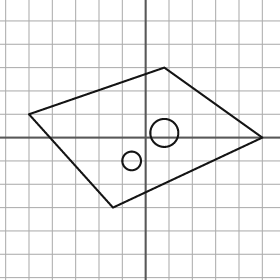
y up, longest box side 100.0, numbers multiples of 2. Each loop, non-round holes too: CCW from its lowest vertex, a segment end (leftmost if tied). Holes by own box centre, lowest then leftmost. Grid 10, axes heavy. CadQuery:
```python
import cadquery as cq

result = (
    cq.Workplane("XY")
    .moveTo(-14.0, -30.0)
    .lineTo(50.0, 0.0)
    .lineTo(8.0, 30.0)
    .lineTo(-50.0, 10.0)
    .close()
    .moveTo(-6.0, -10.0)
    .circle(4.0)
    .moveTo(8.0, 2.0)
    .circle(6.0)
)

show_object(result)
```